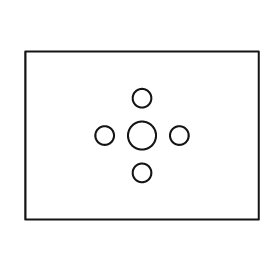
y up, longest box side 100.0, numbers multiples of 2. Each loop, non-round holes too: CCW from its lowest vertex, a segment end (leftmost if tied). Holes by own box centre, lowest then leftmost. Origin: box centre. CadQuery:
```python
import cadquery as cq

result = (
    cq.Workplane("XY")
    .moveTo(-50.0, -36.0)
    .lineTo(50.0, -36.0)
    .lineTo(50.0, 36.0)
    .lineTo(-50.0, 36.0)
    .close()
    .moveTo(0.0, -16.0)
    .circle(4.0)
    .moveTo(-16.0, 0.0)
    .circle(4.0)
    .moveTo(0.0, 0.0)
    .circle(6.0)
    .moveTo(16.0, 0.0)
    .circle(4.0)
    .moveTo(0.0, 16.0)
    .circle(4.0)
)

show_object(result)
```